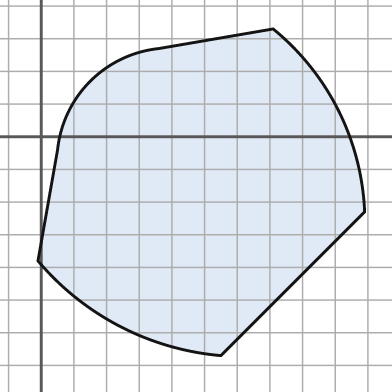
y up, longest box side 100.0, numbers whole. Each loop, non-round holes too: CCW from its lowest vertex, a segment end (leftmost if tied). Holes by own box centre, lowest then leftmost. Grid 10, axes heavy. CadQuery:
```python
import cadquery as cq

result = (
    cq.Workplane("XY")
    .moveTo(55.0, -67.0)
    .lineTo(99.0, -23.0)
    .threePointArc((91.0, 8.0), (71.0, 33.0))
    .lineTo(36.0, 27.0)
    .threePointArc((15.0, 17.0), (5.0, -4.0))
    .lineTo(-1.0, -38.0)
    .threePointArc((24.0, -58.0), (55.0, -67.0))
    .close()
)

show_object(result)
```